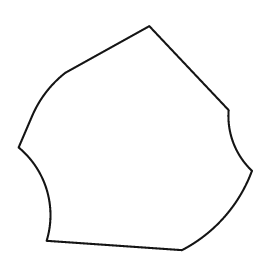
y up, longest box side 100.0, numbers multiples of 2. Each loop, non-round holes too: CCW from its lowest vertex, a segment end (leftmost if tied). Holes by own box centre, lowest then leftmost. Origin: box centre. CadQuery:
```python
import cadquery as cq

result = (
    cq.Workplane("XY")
    .moveTo(20.0, -48.0)
    .threePointArc((38.0, -34.0), (50.0, -14.0))
    .threePointArc((42.0, -2.0), (40.0, 12.0))
    .lineTo(6.0, 48.0)
    .lineTo(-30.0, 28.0)
    .threePointArc((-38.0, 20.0), (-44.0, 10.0))
    .lineTo(-50.0, -4.0)
    .threePointArc((-38.0, -22.0), (-38.0, -44.0))
    .close()
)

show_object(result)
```